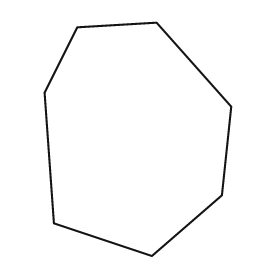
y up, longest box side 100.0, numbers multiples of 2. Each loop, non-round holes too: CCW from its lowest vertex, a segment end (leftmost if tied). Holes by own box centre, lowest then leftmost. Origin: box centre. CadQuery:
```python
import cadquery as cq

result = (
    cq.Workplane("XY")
    .moveTo(6.0, -50.0)
    .lineTo(36.0, -24.0)
    .lineTo(40.0, 14.0)
    .lineTo(8.0, 50.0)
    .lineTo(-26.0, 48.0)
    .lineTo(-40.0, 20.0)
    .lineTo(-36.0, -36.0)
    .close()
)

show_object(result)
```